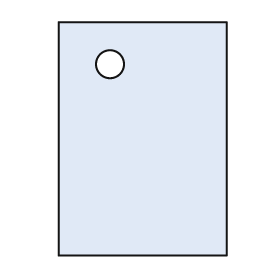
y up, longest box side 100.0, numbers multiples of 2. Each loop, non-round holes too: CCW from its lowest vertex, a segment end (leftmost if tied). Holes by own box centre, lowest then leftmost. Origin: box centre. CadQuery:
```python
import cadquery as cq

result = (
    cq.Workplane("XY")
    .moveTo(-36.0, -50.0)
    .lineTo(36.0, -50.0)
    .lineTo(36.0, 50.0)
    .lineTo(-36.0, 50.0)
    .close()
    .moveTo(-14.0, 32.0)
    .circle(6.0)
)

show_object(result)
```